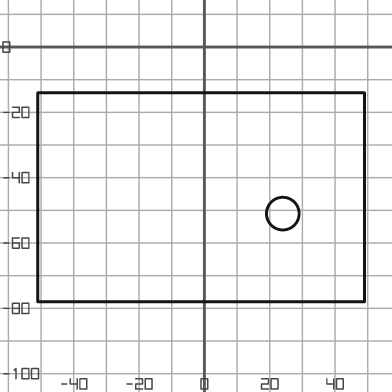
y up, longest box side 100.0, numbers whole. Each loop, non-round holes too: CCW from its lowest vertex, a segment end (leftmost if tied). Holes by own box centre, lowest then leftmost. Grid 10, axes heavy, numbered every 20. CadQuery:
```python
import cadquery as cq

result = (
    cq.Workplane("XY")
    .moveTo(-51.0, -78.0)
    .lineTo(49.0, -78.0)
    .lineTo(49.0, -14.0)
    .lineTo(-51.0, -14.0)
    .close()
    .moveTo(24.0, -51.0)
    .circle(5.0)
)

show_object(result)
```